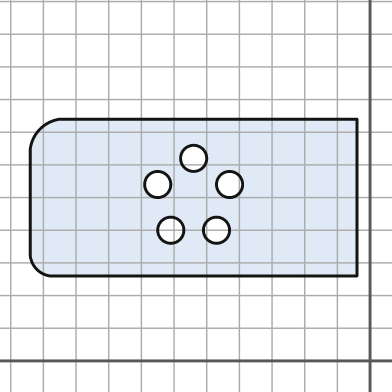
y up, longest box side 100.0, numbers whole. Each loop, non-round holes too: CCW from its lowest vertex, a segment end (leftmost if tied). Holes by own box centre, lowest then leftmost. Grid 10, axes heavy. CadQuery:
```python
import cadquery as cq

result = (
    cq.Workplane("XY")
    .moveTo(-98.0, 26.0)
    .lineTo(-4.0, 26.0)
    .lineTo(-4.0, 74.0)
    .lineTo(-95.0, 74.0)
    .threePointArc((-101.0, 71.0), (-104.0, 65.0))
    .lineTo(-104.0, 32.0)
    .threePointArc((-102.0, 28.0), (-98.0, 26.0))
    .close()
    .moveTo(-61.0, 40.0)
    .circle(4.0)
    .moveTo(-47.0, 40.0)
    .circle(4.0)
    .moveTo(-65.0, 54.0)
    .circle(4.0)
    .moveTo(-43.0, 54.0)
    .circle(4.0)
    .moveTo(-54.0, 62.0)
    .circle(4.0)
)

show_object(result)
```